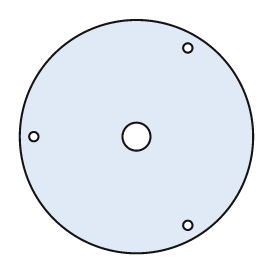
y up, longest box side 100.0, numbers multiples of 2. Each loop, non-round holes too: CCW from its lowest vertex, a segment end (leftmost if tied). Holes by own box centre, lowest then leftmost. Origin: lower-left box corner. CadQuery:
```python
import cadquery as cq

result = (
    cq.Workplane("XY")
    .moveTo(50.0, 50.0)
    .circle(50.0)
    .moveTo(72.0, 12.0)
    .circle(2.0)
    .moveTo(6.0, 50.0)
    .circle(2.0)
    .moveTo(50.0, 50.0)
    .circle(6.0)
    .moveTo(72.0, 88.0)
    .circle(2.0)
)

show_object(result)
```